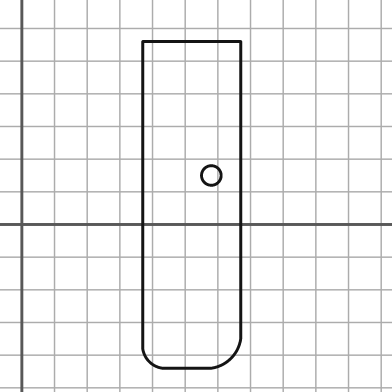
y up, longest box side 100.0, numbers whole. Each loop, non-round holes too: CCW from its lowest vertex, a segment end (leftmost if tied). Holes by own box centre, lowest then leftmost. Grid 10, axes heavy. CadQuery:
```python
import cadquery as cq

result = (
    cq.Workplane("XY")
    .moveTo(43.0, -44.0)
    .lineTo(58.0, -44.0)
    .threePointArc((64.0, -41.0), (67.0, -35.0))
    .lineTo(67.0, 56.0)
    .lineTo(37.0, 56.0)
    .lineTo(37.0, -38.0)
    .threePointArc((39.0, -42.0), (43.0, -44.0))
    .close()
    .moveTo(58.0, 15.0)
    .circle(3.0)
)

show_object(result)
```